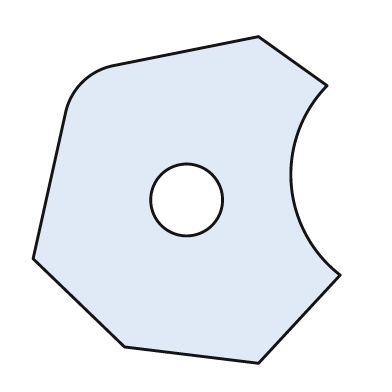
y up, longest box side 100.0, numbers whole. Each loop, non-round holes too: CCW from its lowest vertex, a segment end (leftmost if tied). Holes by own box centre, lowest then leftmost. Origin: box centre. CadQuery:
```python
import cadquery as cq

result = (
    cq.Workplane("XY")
    .moveTo(22.0, -50.0)
    .lineTo(47.0, -23.0)
    .threePointArc((32.0, 5.0), (43.0, 35.0))
    .lineTo(22.0, 50.0)
    .lineTo(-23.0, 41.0)
    .threePointArc((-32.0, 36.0), (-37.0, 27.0))
    .lineTo(-47.0, -18.0)
    .lineTo(-19.0, -45.0)
    .close()
    .moveTo(0.0, 0.0)
    .circle(11.0)
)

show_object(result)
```